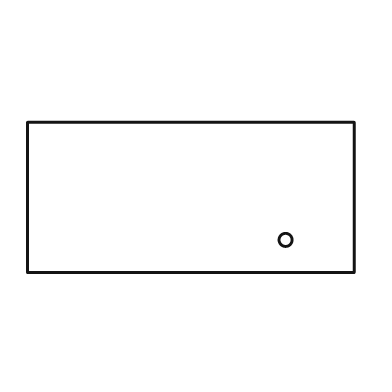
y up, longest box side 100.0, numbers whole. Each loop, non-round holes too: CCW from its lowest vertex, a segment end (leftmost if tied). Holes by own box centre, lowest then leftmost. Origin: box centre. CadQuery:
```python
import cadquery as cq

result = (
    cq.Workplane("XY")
    .moveTo(-50.0, -23.0)
    .lineTo(50.0, -23.0)
    .lineTo(50.0, 23.0)
    .lineTo(-50.0, 23.0)
    .close()
    .moveTo(29.0, -13.0)
    .circle(2.0)
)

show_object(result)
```